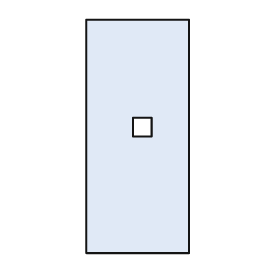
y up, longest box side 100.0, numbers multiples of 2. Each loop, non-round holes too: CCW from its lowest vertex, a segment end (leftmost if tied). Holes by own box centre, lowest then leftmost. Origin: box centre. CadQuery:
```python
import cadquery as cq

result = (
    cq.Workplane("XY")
    .moveTo(-22.0, -50.0)
    .lineTo(22.0, -50.0)
    .lineTo(22.0, 50.0)
    .lineTo(-22.0, 50.0)
    .close()
    .moveTo(-2.0, 0.0)
    .lineTo(6.0, 0.0)
    .lineTo(6.0, 8.0)
    .lineTo(-2.0, 8.0)
    .close()
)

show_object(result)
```